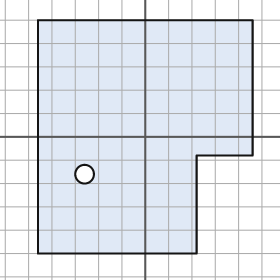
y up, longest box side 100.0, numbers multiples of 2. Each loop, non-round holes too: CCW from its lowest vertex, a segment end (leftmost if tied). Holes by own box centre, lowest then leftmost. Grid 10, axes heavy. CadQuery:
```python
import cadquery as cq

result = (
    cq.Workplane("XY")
    .moveTo(-46.0, -50.0)
    .lineTo(22.0, -50.0)
    .lineTo(22.0, -8.0)
    .lineTo(46.0, -8.0)
    .lineTo(46.0, 50.0)
    .lineTo(-46.0, 50.0)
    .close()
    .moveTo(-26.0, -16.0)
    .circle(4.0)
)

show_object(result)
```